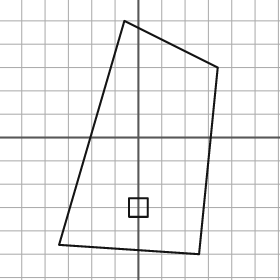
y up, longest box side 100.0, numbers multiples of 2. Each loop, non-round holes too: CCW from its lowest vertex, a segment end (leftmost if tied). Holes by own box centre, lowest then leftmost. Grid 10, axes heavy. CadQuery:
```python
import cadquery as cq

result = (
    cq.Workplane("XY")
    .moveTo(26.0, -50.0)
    .lineTo(34.0, 30.0)
    .lineTo(-6.0, 50.0)
    .lineTo(-34.0, -46.0)
    .close()
    .moveTo(-4.0, -34.0)
    .lineTo(4.0, -34.0)
    .lineTo(4.0, -26.0)
    .lineTo(-4.0, -26.0)
    .close()
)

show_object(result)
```